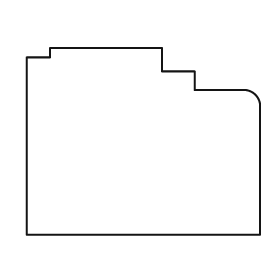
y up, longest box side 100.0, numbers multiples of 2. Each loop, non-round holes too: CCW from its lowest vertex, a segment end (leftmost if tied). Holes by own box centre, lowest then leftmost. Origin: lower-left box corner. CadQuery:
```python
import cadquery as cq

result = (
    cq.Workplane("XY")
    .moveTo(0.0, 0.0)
    .lineTo(100.0, 0.0)
    .lineTo(100.0, 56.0)
    .threePointArc((98.0, 60.0), (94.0, 62.0))
    .lineTo(72.0, 62.0)
    .lineTo(72.0, 70.0)
    .lineTo(58.0, 70.0)
    .lineTo(58.0, 80.0)
    .lineTo(10.0, 80.0)
    .lineTo(10.0, 76.0)
    .lineTo(0.0, 76.0)
    .close()
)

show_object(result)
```